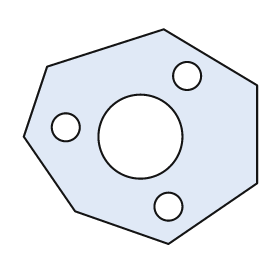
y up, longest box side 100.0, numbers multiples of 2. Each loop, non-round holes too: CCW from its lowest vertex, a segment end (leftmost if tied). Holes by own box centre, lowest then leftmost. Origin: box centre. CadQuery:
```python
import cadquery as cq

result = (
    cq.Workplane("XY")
    .moveTo(12.0, -46.0)
    .lineTo(50.0, -20.0)
    .lineTo(50.0, 22.0)
    .lineTo(10.0, 46.0)
    .lineTo(-40.0, 30.0)
    .lineTo(-50.0, 0.0)
    .lineTo(-28.0, -32.0)
    .close()
    .moveTo(12.0, -30.0)
    .circle(6.0)
    .moveTo(0.0, 0.0)
    .circle(18.0)
    .moveTo(-32.0, 4.0)
    .circle(6.0)
    .moveTo(20.0, 26.0)
    .circle(6.0)
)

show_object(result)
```